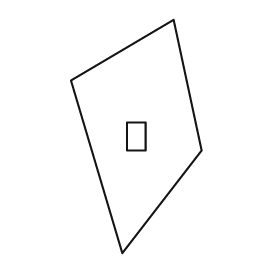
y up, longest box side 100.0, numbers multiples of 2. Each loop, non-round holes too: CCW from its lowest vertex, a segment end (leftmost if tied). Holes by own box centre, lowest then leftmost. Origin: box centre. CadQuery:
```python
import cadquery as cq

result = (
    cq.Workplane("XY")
    .moveTo(-6.0, -50.0)
    .lineTo(28.0, -6.0)
    .lineTo(16.0, 50.0)
    .lineTo(-28.0, 24.0)
    .close()
    .moveTo(-4.0, -6.0)
    .lineTo(4.0, -6.0)
    .lineTo(4.0, 6.0)
    .lineTo(-4.0, 6.0)
    .close()
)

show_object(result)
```